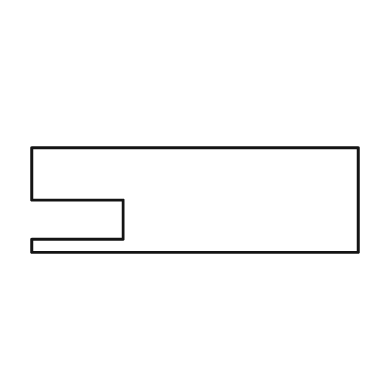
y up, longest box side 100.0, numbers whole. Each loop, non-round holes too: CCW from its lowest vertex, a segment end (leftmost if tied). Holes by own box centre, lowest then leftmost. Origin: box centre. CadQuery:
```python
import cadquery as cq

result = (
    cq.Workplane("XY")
    .moveTo(-50.0, -16.0)
    .lineTo(50.0, -16.0)
    .lineTo(50.0, 16.0)
    .lineTo(-50.0, 16.0)
    .lineTo(-50.0, 0.0)
    .lineTo(-22.0, 0.0)
    .lineTo(-22.0, -12.0)
    .lineTo(-50.0, -12.0)
    .close()
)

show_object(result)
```